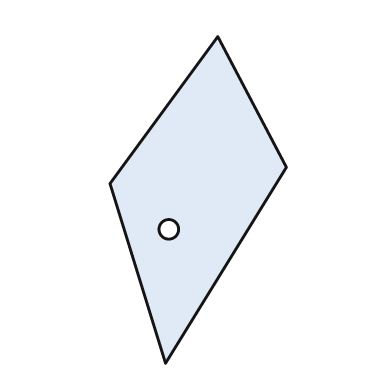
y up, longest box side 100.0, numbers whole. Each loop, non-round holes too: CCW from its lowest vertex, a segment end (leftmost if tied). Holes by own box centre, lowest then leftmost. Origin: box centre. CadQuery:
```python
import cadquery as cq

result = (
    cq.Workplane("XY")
    .moveTo(-10.0, -50.0)
    .lineTo(27.0, 10.0)
    .lineTo(6.0, 50.0)
    .lineTo(-27.0, 5.0)
    .close()
    .moveTo(-9.0, -9.0)
    .circle(3.0)
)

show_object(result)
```